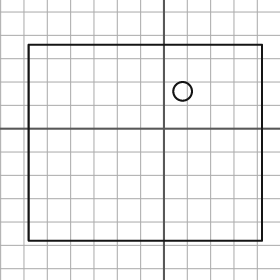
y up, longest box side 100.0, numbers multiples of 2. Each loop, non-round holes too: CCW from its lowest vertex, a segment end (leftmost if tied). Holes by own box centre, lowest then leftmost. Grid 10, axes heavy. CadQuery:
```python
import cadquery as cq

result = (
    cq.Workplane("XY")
    .moveTo(-58.0, -48.0)
    .lineTo(42.0, -48.0)
    .lineTo(42.0, 36.0)
    .lineTo(-58.0, 36.0)
    .close()
    .moveTo(8.0, 16.0)
    .circle(4.0)
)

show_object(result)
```